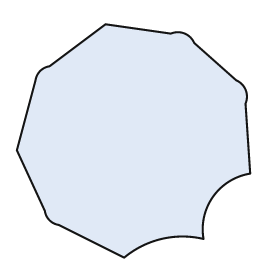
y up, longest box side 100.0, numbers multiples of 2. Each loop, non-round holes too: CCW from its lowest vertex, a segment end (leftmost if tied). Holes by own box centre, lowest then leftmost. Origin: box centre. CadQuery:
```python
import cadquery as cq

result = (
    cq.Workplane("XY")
    .moveTo(-4.0, -50.0)
    .threePointArc((12.0, -42.0), (30.0, -42.0))
    .threePointArc((34.0, -24.0), (50.0, -14.0))
    .lineTo(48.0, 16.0)
    .threePointArc((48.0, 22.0), (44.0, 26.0))
    .lineTo(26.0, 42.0)
    .threePointArc((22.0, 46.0), (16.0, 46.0))
    .lineTo(-12.0, 50.0)
    .lineTo(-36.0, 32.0)
    .threePointArc((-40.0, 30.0), (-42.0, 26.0))
    .lineTo(-50.0, -4.0)
    .lineTo(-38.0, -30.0)
    .threePointArc((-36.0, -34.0), (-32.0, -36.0))
    .close()
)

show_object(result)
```